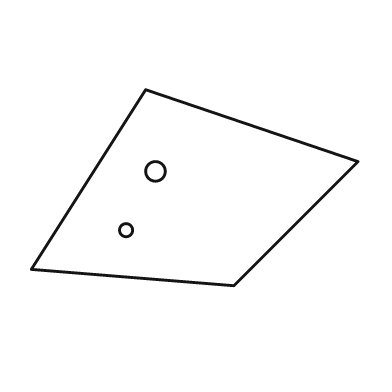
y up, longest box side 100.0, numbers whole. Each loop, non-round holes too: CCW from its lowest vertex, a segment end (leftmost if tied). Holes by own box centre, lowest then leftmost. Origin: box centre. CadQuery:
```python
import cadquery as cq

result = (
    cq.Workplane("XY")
    .moveTo(12.0, -30.0)
    .lineTo(50.0, 8.0)
    .lineTo(-15.0, 30.0)
    .lineTo(-50.0, -25.0)
    .close()
    .moveTo(-21.0, -13.0)
    .circle(2.0)
    .moveTo(-12.0, 5.0)
    .circle(3.0)
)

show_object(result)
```